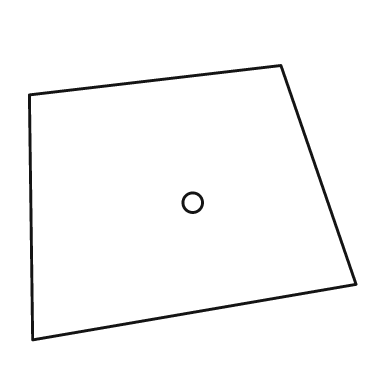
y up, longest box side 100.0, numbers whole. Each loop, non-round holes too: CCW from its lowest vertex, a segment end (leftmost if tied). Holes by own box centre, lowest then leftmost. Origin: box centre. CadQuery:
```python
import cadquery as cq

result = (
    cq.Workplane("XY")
    .moveTo(-49.0, -42.0)
    .lineTo(50.0, -25.0)
    .lineTo(27.0, 42.0)
    .lineTo(-50.0, 33.0)
    .close()
    .moveTo(0.0, 0.0)
    .circle(3.0)
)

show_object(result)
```